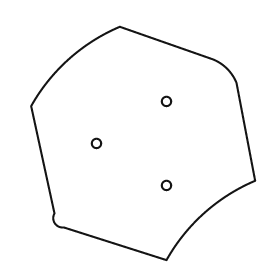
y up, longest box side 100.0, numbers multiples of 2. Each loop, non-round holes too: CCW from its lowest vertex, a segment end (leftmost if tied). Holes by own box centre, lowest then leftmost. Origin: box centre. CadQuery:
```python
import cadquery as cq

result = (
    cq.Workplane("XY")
    .moveTo(10.0, -50.0)
    .threePointArc((26.0, -30.0), (48.0, -16.0))
    .lineTo(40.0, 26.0)
    .threePointArc((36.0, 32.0), (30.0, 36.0))
    .lineTo(-10.0, 50.0)
    .threePointArc((-32.0, 36.0), (-48.0, 16.0))
    .lineTo(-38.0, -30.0)
    .threePointArc((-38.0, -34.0), (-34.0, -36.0))
    .close()
    .moveTo(10.0, -18.0)
    .circle(2.0)
    .moveTo(-20.0, 0.0)
    .circle(2.0)
    .moveTo(10.0, 18.0)
    .circle(2.0)
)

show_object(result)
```